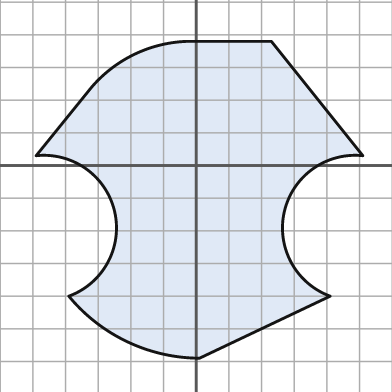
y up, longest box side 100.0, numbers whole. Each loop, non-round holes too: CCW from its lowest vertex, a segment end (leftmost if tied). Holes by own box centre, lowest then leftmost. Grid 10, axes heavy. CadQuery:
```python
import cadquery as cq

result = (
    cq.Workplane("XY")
    .moveTo(1.0, -59.0)
    .lineTo(41.0, -40.0)
    .threePointArc((27.0, -14.0), (51.0, 3.0))
    .lineTo(23.0, 38.0)
    .lineTo(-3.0, 38.0)
    .threePointArc((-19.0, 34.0), (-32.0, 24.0))
    .lineTo(-49.0, 3.0)
    .threePointArc((-25.0, -14.0), (-39.0, -40.0))
    .threePointArc((-21.0, -54.0), (1.0, -59.0))
    .close()
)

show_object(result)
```